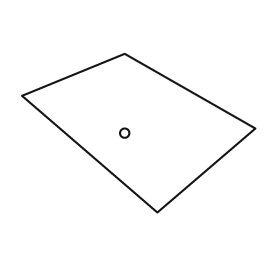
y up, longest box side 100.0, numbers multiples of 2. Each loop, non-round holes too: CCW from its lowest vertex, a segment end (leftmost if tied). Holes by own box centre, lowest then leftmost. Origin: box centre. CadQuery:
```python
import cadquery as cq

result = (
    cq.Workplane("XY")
    .moveTo(8.0, -34.0)
    .lineTo(50.0, 2.0)
    .lineTo(-6.0, 34.0)
    .lineTo(-50.0, 16.0)
    .close()
    .moveTo(-6.0, 0.0)
    .circle(2.0)
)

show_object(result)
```